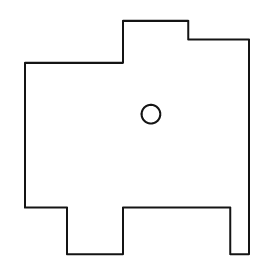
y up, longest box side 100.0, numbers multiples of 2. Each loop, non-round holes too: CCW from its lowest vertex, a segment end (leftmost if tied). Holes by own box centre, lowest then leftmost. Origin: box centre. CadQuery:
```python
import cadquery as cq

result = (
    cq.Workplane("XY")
    .moveTo(-30.0, -50.0)
    .lineTo(-6.0, -50.0)
    .lineTo(-6.0, -30.0)
    .lineTo(40.0, -30.0)
    .lineTo(40.0, -50.0)
    .lineTo(48.0, -50.0)
    .lineTo(48.0, 42.0)
    .lineTo(22.0, 42.0)
    .lineTo(22.0, 50.0)
    .lineTo(-6.0, 50.0)
    .lineTo(-6.0, 32.0)
    .lineTo(-48.0, 32.0)
    .lineTo(-48.0, -30.0)
    .lineTo(-30.0, -30.0)
    .close()
    .moveTo(6.0, 10.0)
    .circle(4.0)
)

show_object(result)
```